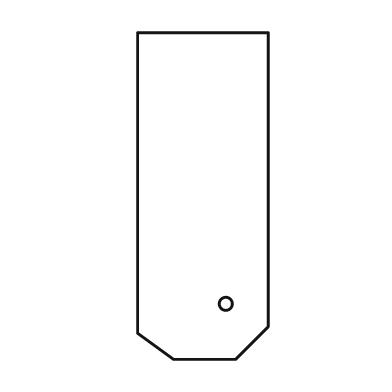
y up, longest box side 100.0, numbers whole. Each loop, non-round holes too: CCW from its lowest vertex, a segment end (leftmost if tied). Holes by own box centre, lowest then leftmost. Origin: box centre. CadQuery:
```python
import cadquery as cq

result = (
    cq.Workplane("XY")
    .moveTo(-9.0, -50.0)
    .lineTo(10.0, -50.0)
    .lineTo(20.0, -40.0)
    .lineTo(20.0, 50.0)
    .lineTo(-20.0, 50.0)
    .lineTo(-20.0, -42.0)
    .close()
    .moveTo(7.0, -33.0)
    .circle(2.0)
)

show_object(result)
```